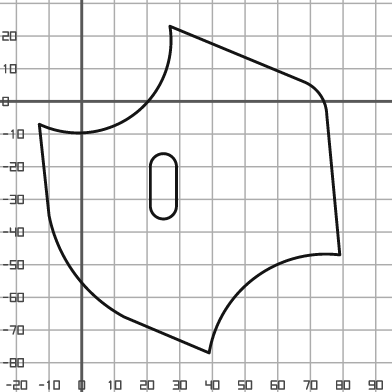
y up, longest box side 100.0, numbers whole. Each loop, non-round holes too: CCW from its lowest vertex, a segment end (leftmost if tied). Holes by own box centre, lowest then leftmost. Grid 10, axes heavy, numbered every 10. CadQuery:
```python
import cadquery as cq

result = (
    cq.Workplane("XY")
    .moveTo(39.0, -77.0)
    .threePointArc((53.0, -54.0), (79.0, -47.0))
    .lineTo(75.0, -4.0)
    .threePointArc((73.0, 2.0), (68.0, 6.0))
    .lineTo(27.0, 23.0)
    .threePointArc((16.0, -4.0), (-13.0, -7.0))
    .lineTo(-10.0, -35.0)
    .threePointArc((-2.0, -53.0), (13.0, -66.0))
    .close()
    .moveTo(21.0, -32.0)
    .threePointArc((25.0, -36.0), (29.0, -32.0))
    .lineTo(29.0, -20.0)
    .threePointArc((25.0, -16.0), (21.0, -20.0))
    .close()
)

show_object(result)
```